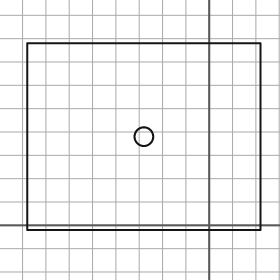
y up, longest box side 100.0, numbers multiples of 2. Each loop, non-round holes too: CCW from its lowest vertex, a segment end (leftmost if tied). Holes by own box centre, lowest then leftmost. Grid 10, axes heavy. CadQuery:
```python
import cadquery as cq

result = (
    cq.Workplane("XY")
    .moveTo(-78.0, -2.0)
    .lineTo(22.0, -2.0)
    .lineTo(22.0, 78.0)
    .lineTo(-78.0, 78.0)
    .close()
    .moveTo(-28.0, 38.0)
    .circle(4.0)
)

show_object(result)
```